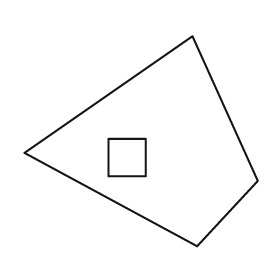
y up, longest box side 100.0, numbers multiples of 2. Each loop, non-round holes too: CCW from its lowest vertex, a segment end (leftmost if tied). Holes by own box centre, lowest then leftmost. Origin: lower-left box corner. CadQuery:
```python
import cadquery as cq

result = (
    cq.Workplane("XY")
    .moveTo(74.0, 0.0)
    .lineTo(100.0, 28.0)
    .lineTo(72.0, 90.0)
    .lineTo(0.0, 40.0)
    .close()
    .moveTo(36.0, 30.0)
    .lineTo(52.0, 30.0)
    .lineTo(52.0, 46.0)
    .lineTo(36.0, 46.0)
    .close()
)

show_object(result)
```